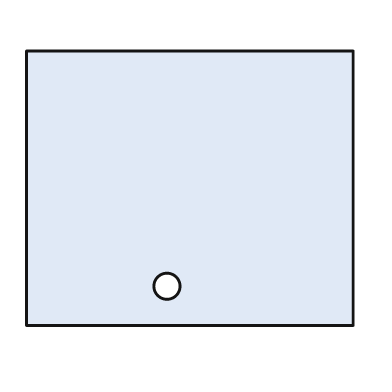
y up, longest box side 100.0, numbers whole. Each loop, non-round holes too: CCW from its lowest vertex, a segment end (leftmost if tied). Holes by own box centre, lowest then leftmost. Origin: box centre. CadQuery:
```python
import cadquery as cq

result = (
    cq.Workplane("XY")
    .moveTo(-50.0, -42.0)
    .lineTo(50.0, -42.0)
    .lineTo(50.0, 42.0)
    .lineTo(-50.0, 42.0)
    .close()
    .moveTo(-7.0, -30.0)
    .circle(4.0)
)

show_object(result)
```